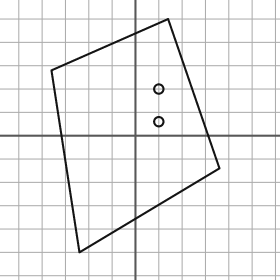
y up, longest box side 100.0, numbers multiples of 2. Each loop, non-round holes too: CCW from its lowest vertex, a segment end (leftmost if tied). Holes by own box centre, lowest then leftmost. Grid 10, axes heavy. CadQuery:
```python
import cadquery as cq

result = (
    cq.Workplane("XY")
    .moveTo(-24.0, -50.0)
    .lineTo(36.0, -14.0)
    .lineTo(14.0, 50.0)
    .lineTo(-36.0, 28.0)
    .close()
    .moveTo(10.0, 6.0)
    .circle(2.0)
    .moveTo(10.0, 20.0)
    .circle(2.0)
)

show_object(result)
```